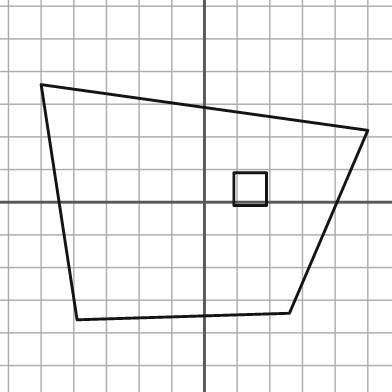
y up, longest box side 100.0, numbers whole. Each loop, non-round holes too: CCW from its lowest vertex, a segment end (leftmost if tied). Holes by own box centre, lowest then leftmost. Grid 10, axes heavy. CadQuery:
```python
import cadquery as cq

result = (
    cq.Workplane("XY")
    .moveTo(-39.0, -36.0)
    .lineTo(26.0, -34.0)
    .lineTo(50.0, 22.0)
    .lineTo(-50.0, 36.0)
    .close()
    .moveTo(9.0, -1.0)
    .lineTo(19.0, -1.0)
    .lineTo(19.0, 9.0)
    .lineTo(9.0, 9.0)
    .close()
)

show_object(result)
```